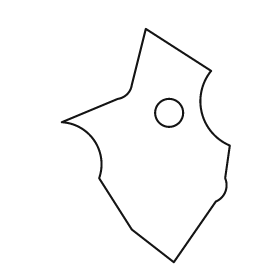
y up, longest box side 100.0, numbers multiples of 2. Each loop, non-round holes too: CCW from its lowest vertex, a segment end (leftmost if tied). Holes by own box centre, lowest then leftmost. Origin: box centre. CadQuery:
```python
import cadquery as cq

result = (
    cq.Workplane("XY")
    .moveTo(12.0, -50.0)
    .lineTo(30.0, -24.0)
    .threePointArc((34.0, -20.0), (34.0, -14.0))
    .lineTo(36.0, 0.0)
    .threePointArc((24.0, 14.0), (28.0, 32.0))
    .lineTo(0.0, 50.0)
    .lineTo(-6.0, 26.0)
    .threePointArc((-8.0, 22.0), (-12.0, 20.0))
    .lineTo(-36.0, 10.0)
    .threePointArc((-22.0, 2.0), (-20.0, -14.0))
    .lineTo(-6.0, -36.0)
    .close()
    .moveTo(10.0, 14.0)
    .circle(6.0)
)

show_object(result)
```